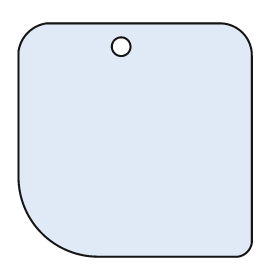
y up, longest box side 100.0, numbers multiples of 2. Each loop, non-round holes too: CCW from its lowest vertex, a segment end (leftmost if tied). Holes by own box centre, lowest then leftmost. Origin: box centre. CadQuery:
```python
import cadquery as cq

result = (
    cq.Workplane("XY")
    .moveTo(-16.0, -50.0)
    .lineTo(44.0, -50.0)
    .threePointArc((48.0, -48.0), (50.0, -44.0))
    .lineTo(50.0, 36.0)
    .threePointArc((46.0, 46.0), (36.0, 50.0))
    .lineTo(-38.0, 50.0)
    .threePointArc((-46.0, 46.0), (-50.0, 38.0))
    .lineTo(-50.0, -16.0)
    .threePointArc((-40.0, -40.0), (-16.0, -50.0))
    .close()
    .moveTo(-6.0, 40.0)
    .circle(4.0)
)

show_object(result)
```